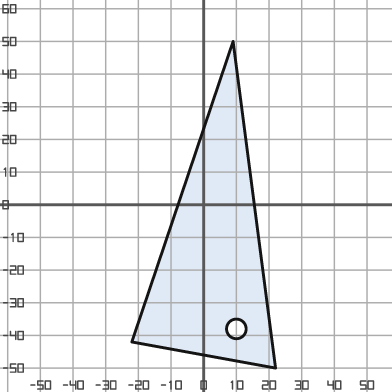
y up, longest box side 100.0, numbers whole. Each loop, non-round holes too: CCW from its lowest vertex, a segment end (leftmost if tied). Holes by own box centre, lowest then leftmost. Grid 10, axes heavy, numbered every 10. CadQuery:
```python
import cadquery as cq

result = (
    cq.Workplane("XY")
    .moveTo(22.0, -50.0)
    .lineTo(9.0, 50.0)
    .lineTo(-22.0, -42.0)
    .close()
    .moveTo(10.0, -38.0)
    .circle(3.0)
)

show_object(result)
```